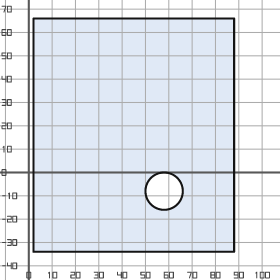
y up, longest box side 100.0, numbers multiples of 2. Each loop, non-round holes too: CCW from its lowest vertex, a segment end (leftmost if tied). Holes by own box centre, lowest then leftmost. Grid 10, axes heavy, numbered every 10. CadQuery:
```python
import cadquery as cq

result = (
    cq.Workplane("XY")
    .moveTo(2.0, -34.0)
    .lineTo(88.0, -34.0)
    .lineTo(88.0, 66.0)
    .lineTo(2.0, 66.0)
    .close()
    .moveTo(58.0, -8.0)
    .circle(8.0)
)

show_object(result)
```